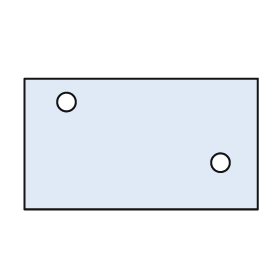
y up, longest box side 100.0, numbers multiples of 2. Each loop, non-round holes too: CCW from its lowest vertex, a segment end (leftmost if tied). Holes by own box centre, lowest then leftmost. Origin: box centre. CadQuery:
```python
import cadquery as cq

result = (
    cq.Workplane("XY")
    .moveTo(-50.0, -28.0)
    .lineTo(50.0, -28.0)
    .lineTo(50.0, 28.0)
    .lineTo(-50.0, 28.0)
    .close()
    .moveTo(34.0, -8.0)
    .circle(4.0)
    .moveTo(-32.0, 18.0)
    .circle(4.0)
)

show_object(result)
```